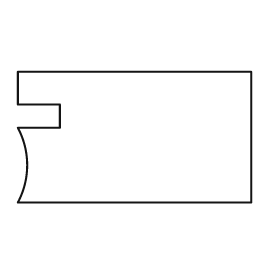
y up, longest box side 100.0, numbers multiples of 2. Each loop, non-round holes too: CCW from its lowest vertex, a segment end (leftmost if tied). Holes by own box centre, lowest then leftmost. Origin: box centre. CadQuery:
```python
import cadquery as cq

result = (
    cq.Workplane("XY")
    .moveTo(-50.0, -28.0)
    .lineTo(50.0, -28.0)
    .lineTo(50.0, 28.0)
    .lineTo(-50.0, 28.0)
    .lineTo(-50.0, 14.0)
    .lineTo(-32.0, 14.0)
    .lineTo(-32.0, 4.0)
    .lineTo(-50.0, 4.0)
    .threePointArc((-46.0, -12.0), (-50.0, -28.0))
    .close()
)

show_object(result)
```